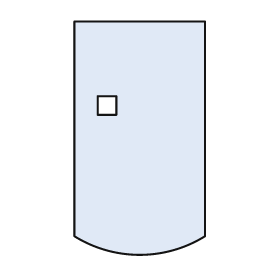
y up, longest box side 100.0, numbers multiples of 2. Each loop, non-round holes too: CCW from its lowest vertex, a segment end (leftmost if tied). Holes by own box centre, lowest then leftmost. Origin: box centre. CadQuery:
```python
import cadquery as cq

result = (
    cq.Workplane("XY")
    .moveTo(-28.0, -42.0)
    .threePointArc((0.0, -50.0), (28.0, -42.0))
    .lineTo(28.0, 50.0)
    .lineTo(-28.0, 50.0)
    .close()
    .moveTo(-18.0, 10.0)
    .lineTo(-10.0, 10.0)
    .lineTo(-10.0, 18.0)
    .lineTo(-18.0, 18.0)
    .close()
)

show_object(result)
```